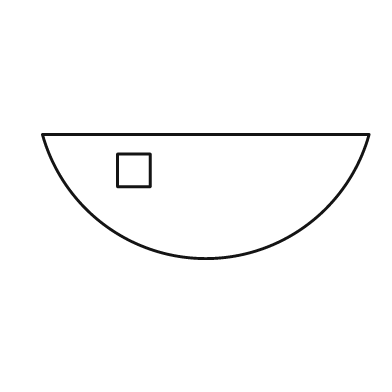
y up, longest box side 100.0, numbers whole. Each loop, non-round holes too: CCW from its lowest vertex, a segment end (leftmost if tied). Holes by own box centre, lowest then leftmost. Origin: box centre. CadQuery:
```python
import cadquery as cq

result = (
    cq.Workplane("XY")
    .moveTo(-50.0, 19.0)
    .threePointArc((0.0, -19.0), (50.0, 19.0))
    .close()
    .moveTo(-27.0, 3.0)
    .lineTo(-17.0, 3.0)
    .lineTo(-17.0, 13.0)
    .lineTo(-27.0, 13.0)
    .close()
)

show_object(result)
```